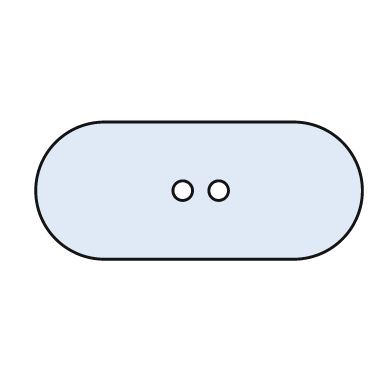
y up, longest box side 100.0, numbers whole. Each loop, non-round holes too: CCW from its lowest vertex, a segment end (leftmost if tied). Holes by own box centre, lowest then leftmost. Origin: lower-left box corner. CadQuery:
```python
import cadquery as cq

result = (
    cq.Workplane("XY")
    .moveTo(21.0, 0.0)
    .lineTo(79.0, 0.0)
    .threePointArc((100.0, 21.0), (79.0, 42.0))
    .lineTo(21.0, 42.0)
    .threePointArc((0.0, 21.0), (21.0, 0.0))
    .close()
    .moveTo(45.0, 21.0)
    .circle(3.0)
    .moveTo(56.0, 21.0)
    .circle(3.0)
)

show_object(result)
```